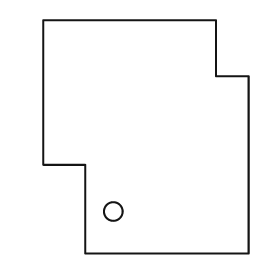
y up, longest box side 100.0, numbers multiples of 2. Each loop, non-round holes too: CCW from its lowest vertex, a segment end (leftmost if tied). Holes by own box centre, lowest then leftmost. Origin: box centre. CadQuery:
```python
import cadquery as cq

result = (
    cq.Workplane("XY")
    .moveTo(-26.0, -50.0)
    .lineTo(44.0, -50.0)
    .lineTo(44.0, 26.0)
    .lineTo(30.0, 26.0)
    .lineTo(30.0, 50.0)
    .lineTo(-44.0, 50.0)
    .lineTo(-44.0, -12.0)
    .lineTo(-26.0, -12.0)
    .close()
    .moveTo(-14.0, -32.0)
    .circle(4.0)
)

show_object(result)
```